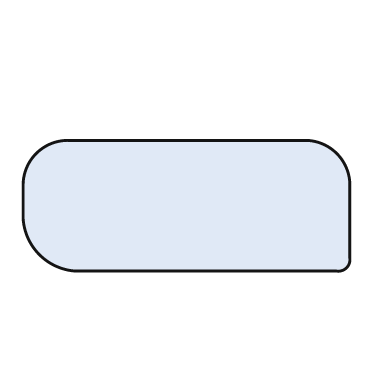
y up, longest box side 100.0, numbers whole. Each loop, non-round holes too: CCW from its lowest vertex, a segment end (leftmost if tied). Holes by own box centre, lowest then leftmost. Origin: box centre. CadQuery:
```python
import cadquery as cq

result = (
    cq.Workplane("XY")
    .moveTo(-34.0, -20.0)
    .lineTo(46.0, -20.0)
    .threePointArc((49.0, -19.0), (50.0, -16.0))
    .lineTo(50.0, 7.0)
    .threePointArc((46.0, 16.0), (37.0, 20.0))
    .lineTo(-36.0, 20.0)
    .threePointArc((-46.0, 16.0), (-50.0, 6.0))
    .lineTo(-50.0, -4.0)
    .threePointArc((-45.0, -15.0), (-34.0, -20.0))
    .close()
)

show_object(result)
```